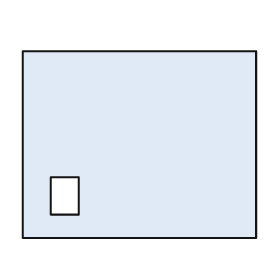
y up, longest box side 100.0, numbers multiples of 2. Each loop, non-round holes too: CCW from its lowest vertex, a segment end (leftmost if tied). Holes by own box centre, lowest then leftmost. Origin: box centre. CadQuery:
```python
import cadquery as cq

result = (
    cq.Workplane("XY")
    .moveTo(-50.0, -40.0)
    .lineTo(50.0, -40.0)
    .lineTo(50.0, 40.0)
    .lineTo(-50.0, 40.0)
    .close()
    .moveTo(-38.0, -30.0)
    .lineTo(-26.0, -30.0)
    .lineTo(-26.0, -14.0)
    .lineTo(-38.0, -14.0)
    .close()
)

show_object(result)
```